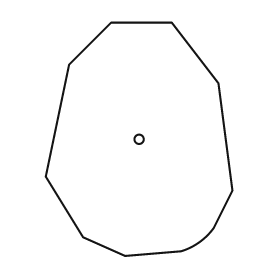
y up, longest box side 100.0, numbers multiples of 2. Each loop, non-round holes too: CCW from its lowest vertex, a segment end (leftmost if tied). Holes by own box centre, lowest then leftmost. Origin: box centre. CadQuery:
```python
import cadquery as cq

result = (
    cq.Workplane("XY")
    .moveTo(-6.0, -50.0)
    .lineTo(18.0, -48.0)
    .threePointArc((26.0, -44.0), (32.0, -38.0))
    .lineTo(40.0, -22.0)
    .lineTo(34.0, 24.0)
    .lineTo(14.0, 50.0)
    .lineTo(-12.0, 50.0)
    .lineTo(-30.0, 32.0)
    .lineTo(-40.0, -16.0)
    .lineTo(-24.0, -42.0)
    .close()
    .moveTo(0.0, 0.0)
    .circle(2.0)
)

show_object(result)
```